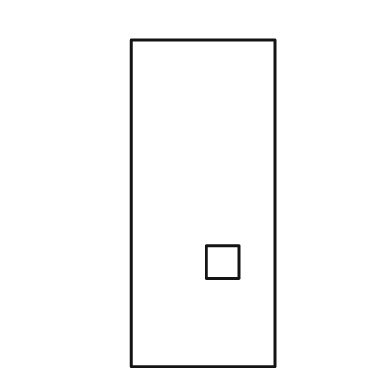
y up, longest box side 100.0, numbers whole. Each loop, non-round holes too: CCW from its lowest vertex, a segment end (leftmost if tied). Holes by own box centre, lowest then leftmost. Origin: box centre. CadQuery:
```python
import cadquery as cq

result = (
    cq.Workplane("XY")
    .moveTo(-22.0, -50.0)
    .lineTo(22.0, -50.0)
    .lineTo(22.0, 50.0)
    .lineTo(-22.0, 50.0)
    .close()
    .moveTo(1.0, -23.0)
    .lineTo(11.0, -23.0)
    .lineTo(11.0, -13.0)
    .lineTo(1.0, -13.0)
    .close()
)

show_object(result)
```